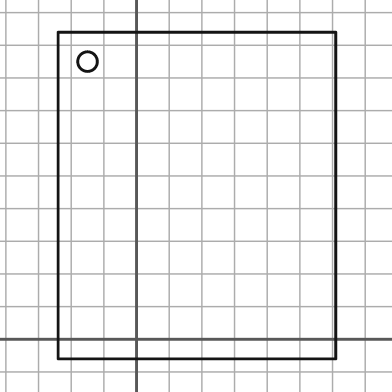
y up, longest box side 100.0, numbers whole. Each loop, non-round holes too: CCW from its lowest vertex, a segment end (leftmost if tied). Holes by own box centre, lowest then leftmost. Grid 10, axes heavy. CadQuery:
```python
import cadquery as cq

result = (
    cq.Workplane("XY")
    .moveTo(-24.0, -6.0)
    .lineTo(61.0, -6.0)
    .lineTo(61.0, 94.0)
    .lineTo(-24.0, 94.0)
    .close()
    .moveTo(-15.0, 85.0)
    .circle(3.0)
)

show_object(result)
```